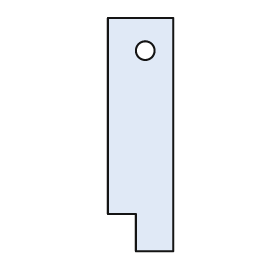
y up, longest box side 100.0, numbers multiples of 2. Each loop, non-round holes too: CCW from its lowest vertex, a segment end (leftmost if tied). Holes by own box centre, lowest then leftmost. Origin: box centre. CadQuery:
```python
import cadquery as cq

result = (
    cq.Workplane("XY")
    .moveTo(-2.0, -50.0)
    .lineTo(14.0, -50.0)
    .lineTo(14.0, 50.0)
    .lineTo(-14.0, 50.0)
    .lineTo(-14.0, -34.0)
    .lineTo(-2.0, -34.0)
    .close()
    .moveTo(2.0, 36.0)
    .circle(4.0)
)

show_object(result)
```